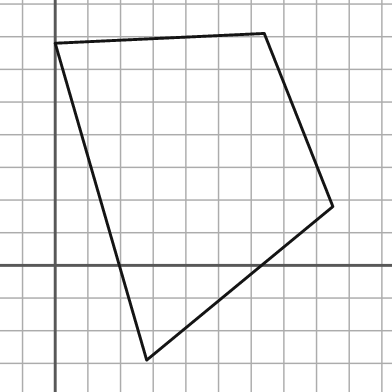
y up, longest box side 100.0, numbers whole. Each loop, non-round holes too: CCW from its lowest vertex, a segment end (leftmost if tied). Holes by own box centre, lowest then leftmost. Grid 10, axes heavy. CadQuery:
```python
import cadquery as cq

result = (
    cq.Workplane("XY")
    .moveTo(28.0, -29.0)
    .lineTo(85.0, 18.0)
    .lineTo(64.0, 71.0)
    .lineTo(0.0, 68.0)
    .close()
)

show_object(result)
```